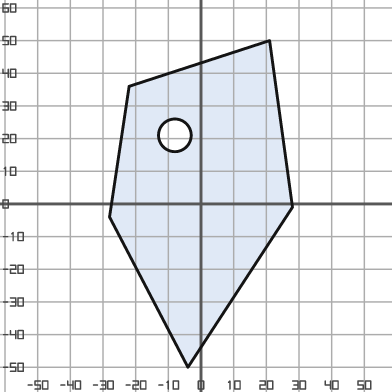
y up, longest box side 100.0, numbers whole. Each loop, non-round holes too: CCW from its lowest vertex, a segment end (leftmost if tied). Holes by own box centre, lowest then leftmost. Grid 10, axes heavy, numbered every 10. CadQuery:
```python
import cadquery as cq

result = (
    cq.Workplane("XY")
    .moveTo(-4.0, -50.0)
    .lineTo(28.0, -1.0)
    .lineTo(21.0, 50.0)
    .lineTo(-22.0, 36.0)
    .lineTo(-28.0, -4.0)
    .close()
    .moveTo(-8.0, 21.0)
    .circle(5.0)
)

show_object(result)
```